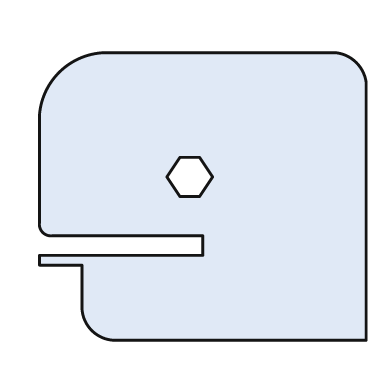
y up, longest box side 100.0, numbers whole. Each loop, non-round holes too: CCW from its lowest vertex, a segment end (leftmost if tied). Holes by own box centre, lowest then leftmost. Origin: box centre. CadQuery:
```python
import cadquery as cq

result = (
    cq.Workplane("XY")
    .moveTo(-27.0, -44.0)
    .lineTo(50.0, -44.0)
    .lineTo(50.0, 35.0)
    .threePointArc((47.0, 41.0), (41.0, 44.0))
    .lineTo(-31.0, 44.0)
    .threePointArc((-44.0, 38.0), (-50.0, 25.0))
    .lineTo(-50.0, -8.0)
    .threePointArc((-49.0, -11.0), (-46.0, -12.0))
    .lineTo(0.0, -12.0)
    .lineTo(0.0, -18.0)
    .lineTo(-50.0, -18.0)
    .lineTo(-50.0, -21.0)
    .lineTo(-37.0, -21.0)
    .lineTo(-37.0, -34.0)
    .threePointArc((-34.0, -41.0), (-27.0, -44.0))
    .close()
    .moveTo(-7.0, 0.0)
    .lineTo(-1.0, 0.0)
    .lineTo(3.0, 6.0)
    .lineTo(-1.0, 12.0)
    .lineTo(-7.0, 12.0)
    .lineTo(-11.0, 6.0)
    .close()
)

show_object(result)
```